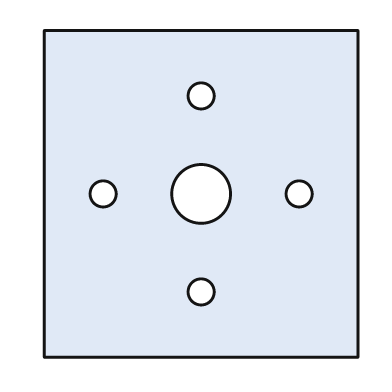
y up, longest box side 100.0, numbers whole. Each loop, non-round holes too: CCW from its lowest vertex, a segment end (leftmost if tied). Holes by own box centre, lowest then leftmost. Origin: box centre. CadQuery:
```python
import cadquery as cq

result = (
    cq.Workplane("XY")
    .moveTo(-48.0, -50.0)
    .lineTo(48.0, -50.0)
    .lineTo(48.0, 50.0)
    .lineTo(-48.0, 50.0)
    .close()
    .moveTo(0.0, -30.0)
    .circle(4.0)
    .moveTo(-30.0, 0.0)
    .circle(4.0)
    .moveTo(0.0, 0.0)
    .circle(9.0)
    .moveTo(30.0, 0.0)
    .circle(4.0)
    .moveTo(0.0, 30.0)
    .circle(4.0)
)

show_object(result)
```